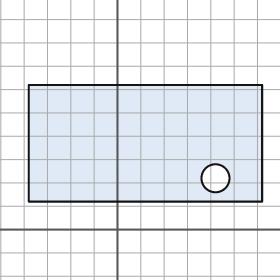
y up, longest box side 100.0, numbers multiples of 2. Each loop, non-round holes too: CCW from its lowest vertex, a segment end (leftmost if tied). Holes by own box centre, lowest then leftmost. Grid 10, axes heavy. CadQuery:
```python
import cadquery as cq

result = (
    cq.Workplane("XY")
    .moveTo(-38.0, 12.0)
    .lineTo(62.0, 12.0)
    .lineTo(62.0, 62.0)
    .lineTo(-38.0, 62.0)
    .close()
    .moveTo(42.0, 22.0)
    .circle(6.0)
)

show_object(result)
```